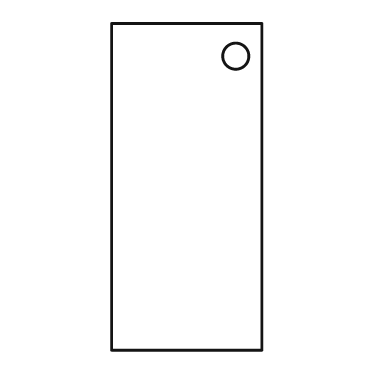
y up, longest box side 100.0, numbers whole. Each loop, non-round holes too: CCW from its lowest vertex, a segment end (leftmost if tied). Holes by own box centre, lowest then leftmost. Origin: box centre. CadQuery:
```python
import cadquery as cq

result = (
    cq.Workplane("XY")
    .moveTo(-23.0, -50.0)
    .lineTo(23.0, -50.0)
    .lineTo(23.0, 50.0)
    .lineTo(-23.0, 50.0)
    .close()
    .moveTo(15.0, 40.0)
    .circle(4.0)
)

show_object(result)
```